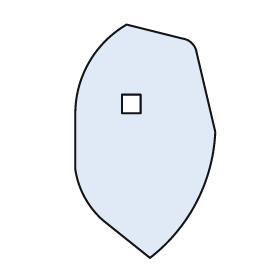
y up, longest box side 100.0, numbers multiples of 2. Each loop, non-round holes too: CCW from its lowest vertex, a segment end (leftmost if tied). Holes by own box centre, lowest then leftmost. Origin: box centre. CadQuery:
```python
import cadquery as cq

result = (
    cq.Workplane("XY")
    .moveTo(2.0, -50.0)
    .threePointArc((22.0, -26.0), (30.0, 4.0))
    .lineTo(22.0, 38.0)
    .threePointArc((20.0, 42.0), (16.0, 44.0))
    .lineTo(-8.0, 50.0)
    .threePointArc((-24.0, 34.0), (-30.0, 12.0))
    .lineTo(-30.0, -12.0)
    .threePointArc((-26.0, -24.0), (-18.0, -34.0))
    .close()
    .moveTo(-10.0, 12.0)
    .lineTo(-2.0, 12.0)
    .lineTo(-2.0, 20.0)
    .lineTo(-10.0, 20.0)
    .close()
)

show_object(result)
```